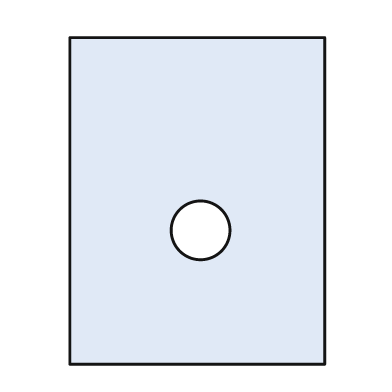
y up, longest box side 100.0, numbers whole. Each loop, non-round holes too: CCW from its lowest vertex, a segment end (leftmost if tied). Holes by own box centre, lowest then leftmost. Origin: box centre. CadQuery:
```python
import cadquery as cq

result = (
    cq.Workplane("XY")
    .moveTo(-39.0, -50.0)
    .lineTo(39.0, -50.0)
    .lineTo(39.0, 50.0)
    .lineTo(-39.0, 50.0)
    .close()
    .moveTo(1.0, -9.0)
    .circle(9.0)
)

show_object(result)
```